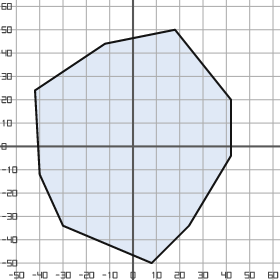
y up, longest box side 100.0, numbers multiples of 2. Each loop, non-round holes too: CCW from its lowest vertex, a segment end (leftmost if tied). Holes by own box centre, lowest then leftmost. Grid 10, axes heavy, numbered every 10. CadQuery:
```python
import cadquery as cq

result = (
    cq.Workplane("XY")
    .moveTo(8.0, -50.0)
    .lineTo(24.0, -34.0)
    .lineTo(42.0, -4.0)
    .lineTo(42.0, 20.0)
    .lineTo(18.0, 50.0)
    .lineTo(-12.0, 44.0)
    .lineTo(-42.0, 24.0)
    .lineTo(-40.0, -12.0)
    .lineTo(-30.0, -34.0)
    .close()
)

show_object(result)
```